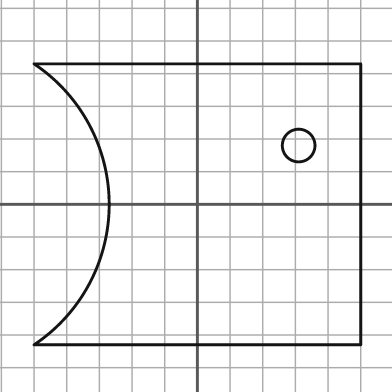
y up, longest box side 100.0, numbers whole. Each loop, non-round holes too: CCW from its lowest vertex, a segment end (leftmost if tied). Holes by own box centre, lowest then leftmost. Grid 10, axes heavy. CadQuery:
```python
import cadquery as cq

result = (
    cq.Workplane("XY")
    .moveTo(-50.0, -43.0)
    .lineTo(50.0, -43.0)
    .lineTo(50.0, 43.0)
    .lineTo(-50.0, 43.0)
    .threePointArc((-27.0, 0.0), (-50.0, -43.0))
    .close()
    .moveTo(31.0, 18.0)
    .circle(5.0)
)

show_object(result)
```